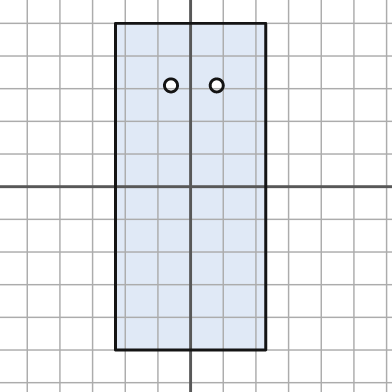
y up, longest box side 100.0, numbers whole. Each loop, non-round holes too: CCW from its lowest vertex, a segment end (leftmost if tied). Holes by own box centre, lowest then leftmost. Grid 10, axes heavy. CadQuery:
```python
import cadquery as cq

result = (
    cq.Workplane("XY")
    .moveTo(-23.0, -50.0)
    .lineTo(23.0, -50.0)
    .lineTo(23.0, 50.0)
    .lineTo(-23.0, 50.0)
    .close()
    .moveTo(-6.0, 31.0)
    .circle(2.0)
    .moveTo(8.0, 31.0)
    .circle(2.0)
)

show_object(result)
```